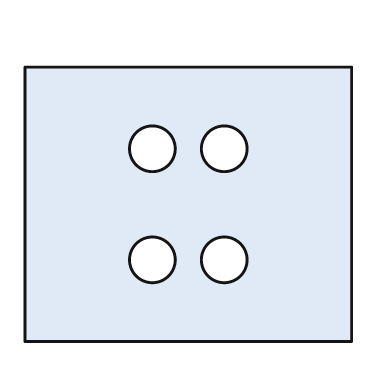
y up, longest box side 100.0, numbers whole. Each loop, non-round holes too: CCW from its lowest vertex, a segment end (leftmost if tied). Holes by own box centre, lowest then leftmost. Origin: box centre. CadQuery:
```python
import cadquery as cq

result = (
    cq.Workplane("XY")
    .moveTo(-50.0, -42.0)
    .lineTo(50.0, -42.0)
    .lineTo(50.0, 42.0)
    .lineTo(-50.0, 42.0)
    .close()
    .moveTo(-11.0, -17.0)
    .circle(7.0)
    .moveTo(11.0, -17.0)
    .circle(7.0)
    .moveTo(-11.0, 17.0)
    .circle(7.0)
    .moveTo(11.0, 17.0)
    .circle(7.0)
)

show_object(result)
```